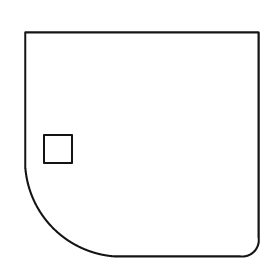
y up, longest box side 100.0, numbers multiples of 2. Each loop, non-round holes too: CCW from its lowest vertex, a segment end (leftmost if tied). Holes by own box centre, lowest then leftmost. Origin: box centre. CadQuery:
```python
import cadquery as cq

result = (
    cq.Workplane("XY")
    .moveTo(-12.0, -48.0)
    .lineTo(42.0, -48.0)
    .threePointArc((48.0, -46.0), (50.0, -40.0))
    .lineTo(50.0, 48.0)
    .lineTo(-50.0, 48.0)
    .lineTo(-50.0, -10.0)
    .threePointArc((-38.0, -36.0), (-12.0, -48.0))
    .close()
    .moveTo(-42.0, -8.0)
    .lineTo(-30.0, -8.0)
    .lineTo(-30.0, 4.0)
    .lineTo(-42.0, 4.0)
    .close()
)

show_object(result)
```